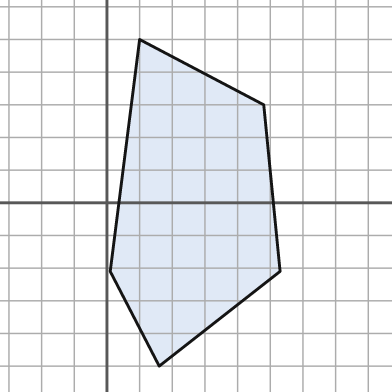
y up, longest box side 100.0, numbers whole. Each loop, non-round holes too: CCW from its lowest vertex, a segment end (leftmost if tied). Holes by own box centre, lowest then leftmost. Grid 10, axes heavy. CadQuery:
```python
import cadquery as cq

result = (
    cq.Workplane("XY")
    .moveTo(16.0, -50.0)
    .lineTo(53.0, -21.0)
    .lineTo(48.0, 30.0)
    .lineTo(10.0, 50.0)
    .lineTo(1.0, -21.0)
    .close()
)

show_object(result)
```